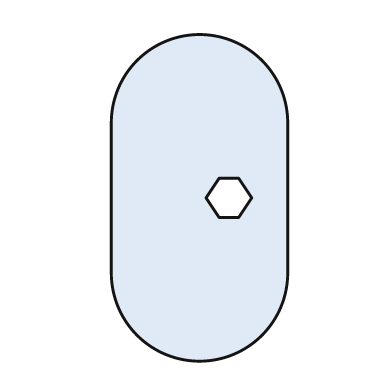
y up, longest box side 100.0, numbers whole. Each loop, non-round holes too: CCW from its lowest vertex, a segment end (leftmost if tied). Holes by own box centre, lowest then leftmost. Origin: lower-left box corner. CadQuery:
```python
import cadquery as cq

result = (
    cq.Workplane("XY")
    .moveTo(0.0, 27.0)
    .threePointArc((27.0, 0.0), (54.0, 27.0))
    .lineTo(54.0, 73.0)
    .threePointArc((27.0, 100.0), (0.0, 73.0))
    .close()
    .moveTo(33.0, 44.0)
    .lineTo(39.0, 44.0)
    .lineTo(43.0, 50.0)
    .lineTo(39.0, 56.0)
    .lineTo(33.0, 56.0)
    .lineTo(29.0, 50.0)
    .close()
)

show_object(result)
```